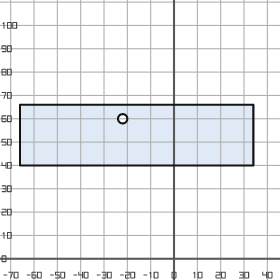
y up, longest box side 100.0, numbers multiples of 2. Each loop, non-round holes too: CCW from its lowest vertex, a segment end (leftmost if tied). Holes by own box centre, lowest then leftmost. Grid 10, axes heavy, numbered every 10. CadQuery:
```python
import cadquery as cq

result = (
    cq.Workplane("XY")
    .moveTo(-66.0, 40.0)
    .lineTo(34.0, 40.0)
    .lineTo(34.0, 66.0)
    .lineTo(-66.0, 66.0)
    .close()
    .moveTo(-22.0, 60.0)
    .circle(2.0)
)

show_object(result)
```